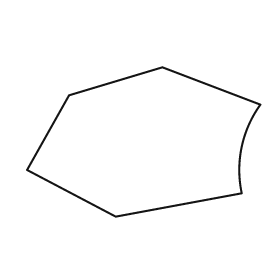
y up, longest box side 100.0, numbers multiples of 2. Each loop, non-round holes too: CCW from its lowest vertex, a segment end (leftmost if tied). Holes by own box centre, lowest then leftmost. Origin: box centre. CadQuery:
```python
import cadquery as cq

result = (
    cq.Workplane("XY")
    .moveTo(-12.0, -32.0)
    .lineTo(42.0, -22.0)
    .threePointArc((42.0, -2.0), (50.0, 16.0))
    .lineTo(8.0, 32.0)
    .lineTo(-32.0, 20.0)
    .lineTo(-50.0, -12.0)
    .close()
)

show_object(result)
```